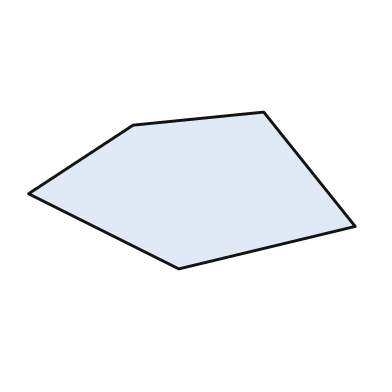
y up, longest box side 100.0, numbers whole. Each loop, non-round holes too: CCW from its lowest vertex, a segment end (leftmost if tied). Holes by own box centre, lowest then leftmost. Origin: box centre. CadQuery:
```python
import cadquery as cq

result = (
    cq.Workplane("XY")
    .moveTo(-4.0, -24.0)
    .lineTo(50.0, -11.0)
    .lineTo(22.0, 24.0)
    .lineTo(-18.0, 20.0)
    .lineTo(-50.0, -1.0)
    .close()
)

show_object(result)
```